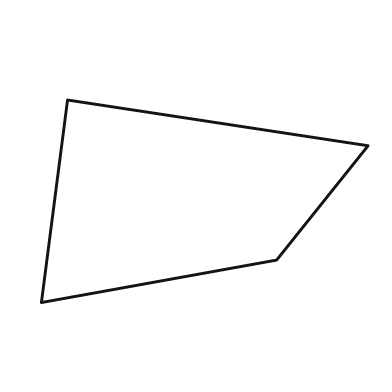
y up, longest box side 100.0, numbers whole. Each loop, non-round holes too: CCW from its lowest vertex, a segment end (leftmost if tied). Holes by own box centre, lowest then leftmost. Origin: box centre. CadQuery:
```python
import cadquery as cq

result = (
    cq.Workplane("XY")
    .moveTo(-50.0, -31.0)
    .lineTo(22.0, -18.0)
    .lineTo(50.0, 17.0)
    .lineTo(-42.0, 31.0)
    .close()
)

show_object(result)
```